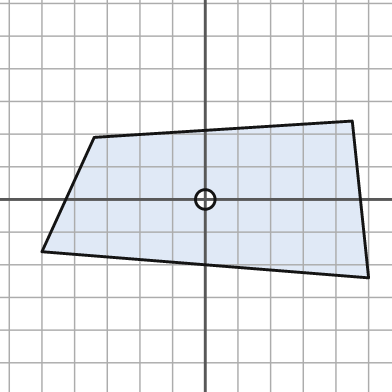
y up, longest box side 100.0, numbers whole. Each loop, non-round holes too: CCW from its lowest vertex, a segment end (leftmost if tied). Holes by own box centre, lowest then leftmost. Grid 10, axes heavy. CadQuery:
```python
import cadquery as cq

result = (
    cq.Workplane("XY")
    .moveTo(50.0, -24.0)
    .lineTo(45.0, 24.0)
    .lineTo(-34.0, 19.0)
    .lineTo(-50.0, -16.0)
    .close()
    .moveTo(0.0, 0.0)
    .circle(3.0)
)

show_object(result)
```